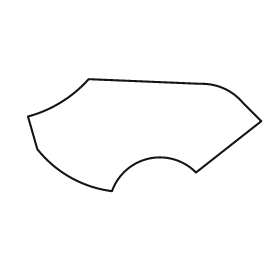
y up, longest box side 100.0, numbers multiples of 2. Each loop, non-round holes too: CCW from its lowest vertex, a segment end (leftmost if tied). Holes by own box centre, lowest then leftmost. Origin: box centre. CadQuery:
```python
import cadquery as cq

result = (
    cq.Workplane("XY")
    .moveTo(-14.0, -24.0)
    .threePointArc((2.0, -10.0), (22.0, -16.0))
    .lineTo(50.0, 6.0)
    .lineTo(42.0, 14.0)
    .threePointArc((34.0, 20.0), (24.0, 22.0))
    .lineTo(-24.0, 24.0)
    .threePointArc((-36.0, 14.0), (-50.0, 8.0))
    .lineTo(-46.0, -6.0)
    .threePointArc((-32.0, -18.0), (-14.0, -24.0))
    .close()
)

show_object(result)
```